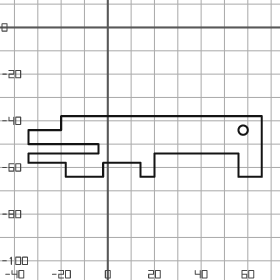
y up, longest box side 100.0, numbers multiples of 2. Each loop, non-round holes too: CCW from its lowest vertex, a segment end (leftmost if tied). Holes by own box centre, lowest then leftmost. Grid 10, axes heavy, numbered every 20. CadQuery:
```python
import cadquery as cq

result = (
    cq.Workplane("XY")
    .moveTo(-18.0, -64.0)
    .lineTo(-2.0, -64.0)
    .lineTo(-2.0, -58.0)
    .lineTo(14.0, -58.0)
    .lineTo(14.0, -64.0)
    .lineTo(20.0, -64.0)
    .lineTo(20.0, -54.0)
    .lineTo(56.0, -54.0)
    .lineTo(56.0, -64.0)
    .lineTo(66.0, -64.0)
    .lineTo(66.0, -38.0)
    .lineTo(-20.0, -38.0)
    .lineTo(-20.0, -44.0)
    .lineTo(-34.0, -44.0)
    .lineTo(-34.0, -50.0)
    .lineTo(-4.0, -50.0)
    .lineTo(-4.0, -54.0)
    .lineTo(-34.0, -54.0)
    .lineTo(-34.0, -58.0)
    .lineTo(-18.0, -58.0)
    .close()
    .moveTo(58.0, -44.0)
    .circle(2.0)
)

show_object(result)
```